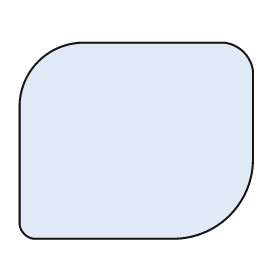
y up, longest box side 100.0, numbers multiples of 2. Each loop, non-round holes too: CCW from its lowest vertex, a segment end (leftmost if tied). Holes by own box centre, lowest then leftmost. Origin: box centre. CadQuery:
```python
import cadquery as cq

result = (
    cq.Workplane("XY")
    .moveTo(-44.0, -42.0)
    .lineTo(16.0, -42.0)
    .threePointArc((40.0, -32.0), (50.0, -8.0))
    .lineTo(50.0, 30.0)
    .threePointArc((46.0, 38.0), (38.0, 42.0))
    .lineTo(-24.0, 42.0)
    .threePointArc((-42.0, 34.0), (-50.0, 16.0))
    .lineTo(-50.0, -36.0)
    .threePointArc((-48.0, -40.0), (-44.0, -42.0))
    .close()
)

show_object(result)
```